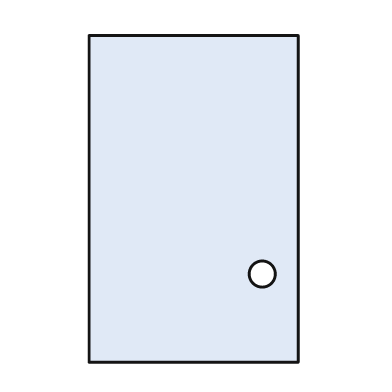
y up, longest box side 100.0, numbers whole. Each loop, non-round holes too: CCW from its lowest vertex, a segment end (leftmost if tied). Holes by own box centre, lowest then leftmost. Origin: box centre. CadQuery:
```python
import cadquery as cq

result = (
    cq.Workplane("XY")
    .moveTo(-32.0, -50.0)
    .lineTo(32.0, -50.0)
    .lineTo(32.0, 50.0)
    .lineTo(-32.0, 50.0)
    .close()
    .moveTo(21.0, -23.0)
    .circle(4.0)
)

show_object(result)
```